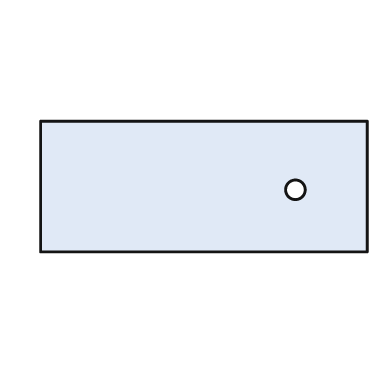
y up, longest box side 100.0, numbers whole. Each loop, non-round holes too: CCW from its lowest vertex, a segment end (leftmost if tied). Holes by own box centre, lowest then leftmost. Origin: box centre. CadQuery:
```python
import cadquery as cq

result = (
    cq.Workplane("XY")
    .moveTo(-50.0, -20.0)
    .lineTo(50.0, -20.0)
    .lineTo(50.0, 20.0)
    .lineTo(-50.0, 20.0)
    .close()
    .moveTo(28.0, -1.0)
    .circle(3.0)
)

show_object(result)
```